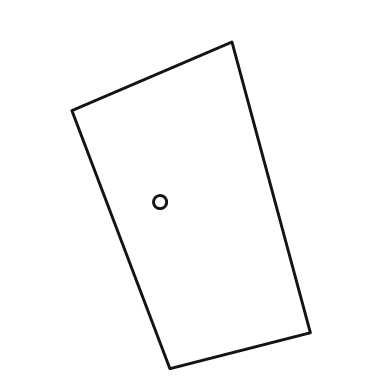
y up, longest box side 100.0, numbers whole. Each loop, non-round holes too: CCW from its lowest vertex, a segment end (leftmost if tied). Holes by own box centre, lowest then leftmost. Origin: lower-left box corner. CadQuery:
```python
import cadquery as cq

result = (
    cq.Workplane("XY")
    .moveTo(30.0, 0.0)
    .lineTo(73.0, 11.0)
    .lineTo(49.0, 100.0)
    .lineTo(0.0, 79.0)
    .close()
    .moveTo(27.0, 51.0)
    .circle(2.0)
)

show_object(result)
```